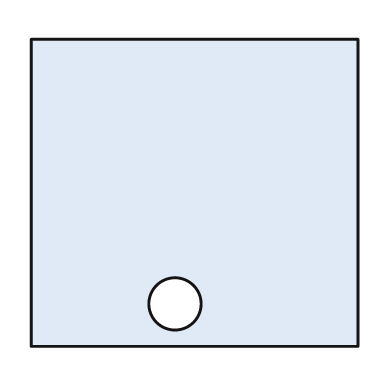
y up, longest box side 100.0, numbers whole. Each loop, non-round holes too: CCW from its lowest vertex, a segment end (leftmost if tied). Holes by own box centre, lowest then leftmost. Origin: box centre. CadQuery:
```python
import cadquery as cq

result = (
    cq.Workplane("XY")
    .moveTo(-50.0, -47.0)
    .lineTo(50.0, -47.0)
    .lineTo(50.0, 47.0)
    .lineTo(-50.0, 47.0)
    .close()
    .moveTo(-6.0, -34.0)
    .circle(8.0)
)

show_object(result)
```